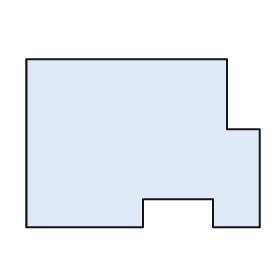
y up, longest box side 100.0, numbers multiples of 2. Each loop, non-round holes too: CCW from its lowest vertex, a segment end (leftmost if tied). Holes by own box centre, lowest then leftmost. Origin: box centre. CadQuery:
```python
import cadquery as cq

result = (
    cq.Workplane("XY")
    .moveTo(-50.0, -36.0)
    .lineTo(0.0, -36.0)
    .lineTo(0.0, -24.0)
    .lineTo(30.0, -24.0)
    .lineTo(30.0, -36.0)
    .lineTo(50.0, -36.0)
    .lineTo(50.0, 6.0)
    .lineTo(36.0, 6.0)
    .lineTo(36.0, 36.0)
    .lineTo(-50.0, 36.0)
    .close()
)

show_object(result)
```